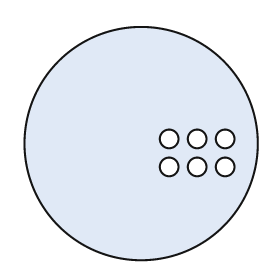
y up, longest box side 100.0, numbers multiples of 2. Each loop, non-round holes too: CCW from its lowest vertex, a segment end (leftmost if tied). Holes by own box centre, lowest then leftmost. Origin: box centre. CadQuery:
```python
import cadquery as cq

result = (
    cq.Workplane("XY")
    .moveTo(0.0, 0.0)
    .circle(50.0)
    .moveTo(12.0, -10.0)
    .circle(4.0)
    .moveTo(24.0, -10.0)
    .circle(4.0)
    .moveTo(36.0, -10.0)
    .circle(4.0)
    .moveTo(12.0, 2.0)
    .circle(4.0)
    .moveTo(24.0, 2.0)
    .circle(4.0)
    .moveTo(36.0, 2.0)
    .circle(4.0)
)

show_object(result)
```